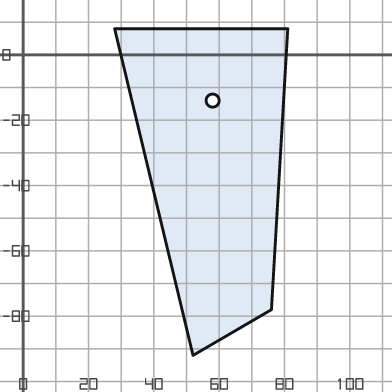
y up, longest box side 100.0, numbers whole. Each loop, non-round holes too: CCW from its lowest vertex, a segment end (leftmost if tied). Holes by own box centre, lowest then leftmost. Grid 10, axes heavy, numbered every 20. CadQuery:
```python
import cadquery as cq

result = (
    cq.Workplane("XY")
    .moveTo(52.0, -92.0)
    .lineTo(76.0, -78.0)
    .lineTo(81.0, 8.0)
    .lineTo(28.0, 8.0)
    .close()
    .moveTo(58.0, -14.0)
    .circle(2.0)
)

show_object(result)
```